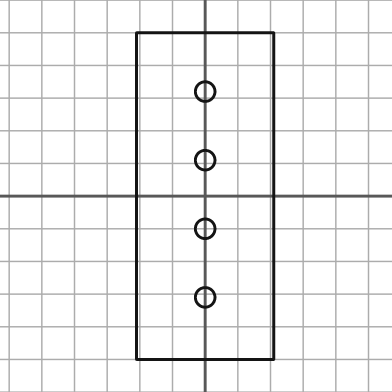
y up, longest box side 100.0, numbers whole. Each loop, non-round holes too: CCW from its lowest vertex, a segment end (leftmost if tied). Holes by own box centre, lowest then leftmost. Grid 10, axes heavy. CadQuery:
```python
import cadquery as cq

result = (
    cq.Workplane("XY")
    .moveTo(-21.0, -50.0)
    .lineTo(21.0, -50.0)
    .lineTo(21.0, 50.0)
    .lineTo(-21.0, 50.0)
    .close()
    .moveTo(0.0, -31.0)
    .circle(3.0)
    .moveTo(0.0, -10.0)
    .circle(3.0)
    .moveTo(0.0, 11.0)
    .circle(3.0)
    .moveTo(0.0, 32.0)
    .circle(3.0)
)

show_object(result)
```